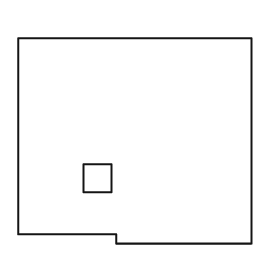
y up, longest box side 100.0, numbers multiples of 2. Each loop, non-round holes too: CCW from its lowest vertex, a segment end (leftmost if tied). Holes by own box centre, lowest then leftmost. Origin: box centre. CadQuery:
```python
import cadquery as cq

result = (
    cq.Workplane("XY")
    .moveTo(-8.0, -44.0)
    .lineTo(50.0, -44.0)
    .lineTo(50.0, 44.0)
    .lineTo(-50.0, 44.0)
    .lineTo(-50.0, -40.0)
    .lineTo(-8.0, -40.0)
    .close()
    .moveTo(-22.0, -22.0)
    .lineTo(-10.0, -22.0)
    .lineTo(-10.0, -10.0)
    .lineTo(-22.0, -10.0)
    .close()
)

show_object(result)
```